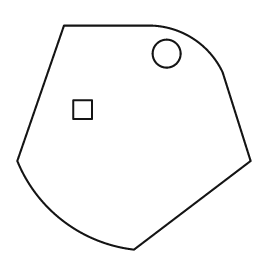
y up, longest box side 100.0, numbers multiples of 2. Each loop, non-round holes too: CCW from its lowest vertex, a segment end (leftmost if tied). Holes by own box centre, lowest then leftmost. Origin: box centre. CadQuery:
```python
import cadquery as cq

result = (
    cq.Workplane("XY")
    .moveTo(0.0, -48.0)
    .lineTo(50.0, -10.0)
    .lineTo(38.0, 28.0)
    .threePointArc((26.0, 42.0), (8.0, 48.0))
    .lineTo(-30.0, 48.0)
    .lineTo(-50.0, -10.0)
    .threePointArc((-30.0, -36.0), (0.0, -48.0))
    .close()
    .moveTo(-26.0, 8.0)
    .lineTo(-18.0, 8.0)
    .lineTo(-18.0, 16.0)
    .lineTo(-26.0, 16.0)
    .close()
    .moveTo(14.0, 36.0)
    .circle(6.0)
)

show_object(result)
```